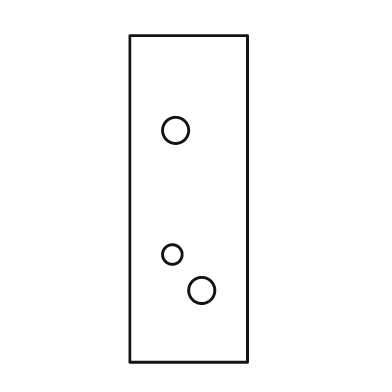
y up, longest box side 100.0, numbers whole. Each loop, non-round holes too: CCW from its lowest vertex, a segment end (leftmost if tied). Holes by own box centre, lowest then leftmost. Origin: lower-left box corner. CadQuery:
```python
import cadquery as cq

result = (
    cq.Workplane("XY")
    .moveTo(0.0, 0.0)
    .lineTo(36.0, 0.0)
    .lineTo(36.0, 100.0)
    .lineTo(0.0, 100.0)
    .close()
    .moveTo(22.0, 22.0)
    .circle(4.0)
    .moveTo(13.0, 33.0)
    .circle(3.0)
    .moveTo(14.0, 71.0)
    .circle(4.0)
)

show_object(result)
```